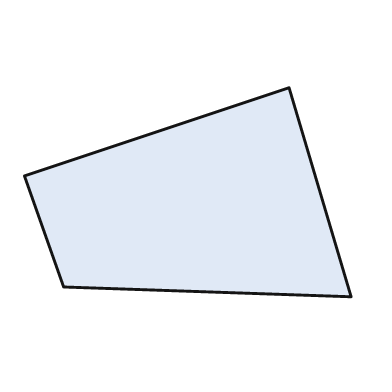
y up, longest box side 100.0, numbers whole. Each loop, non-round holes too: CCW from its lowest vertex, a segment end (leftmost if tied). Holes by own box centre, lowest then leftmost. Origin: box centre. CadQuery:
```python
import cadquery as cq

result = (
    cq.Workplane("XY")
    .moveTo(50.0, -32.0)
    .lineTo(31.0, 32.0)
    .lineTo(-50.0, 5.0)
    .lineTo(-38.0, -29.0)
    .close()
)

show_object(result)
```